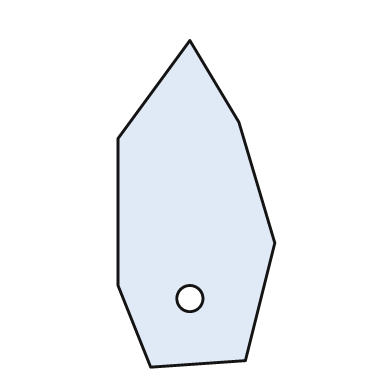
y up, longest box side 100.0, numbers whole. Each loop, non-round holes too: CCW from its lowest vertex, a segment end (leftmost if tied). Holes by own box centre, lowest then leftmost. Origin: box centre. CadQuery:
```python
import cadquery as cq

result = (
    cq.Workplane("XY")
    .moveTo(-14.0, -50.0)
    .lineTo(15.0, -48.0)
    .lineTo(24.0, -12.0)
    .lineTo(13.0, 25.0)
    .lineTo(-2.0, 50.0)
    .lineTo(-24.0, 20.0)
    .lineTo(-24.0, -25.0)
    .close()
    .moveTo(-2.0, -29.0)
    .circle(4.0)
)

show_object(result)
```